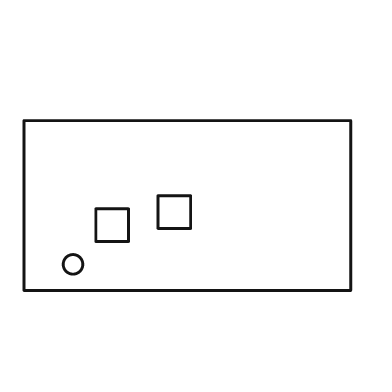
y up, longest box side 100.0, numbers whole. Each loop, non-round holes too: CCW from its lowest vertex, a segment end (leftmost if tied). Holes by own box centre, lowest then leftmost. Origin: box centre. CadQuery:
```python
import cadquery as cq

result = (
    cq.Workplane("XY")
    .moveTo(-50.0, -26.0)
    .lineTo(50.0, -26.0)
    .lineTo(50.0, 26.0)
    .lineTo(-50.0, 26.0)
    .close()
    .moveTo(-35.0, -18.0)
    .circle(3.0)
    .moveTo(-28.0, -11.0)
    .lineTo(-18.0, -11.0)
    .lineTo(-18.0, -1.0)
    .lineTo(-28.0, -1.0)
    .close()
    .moveTo(-9.0, -7.0)
    .lineTo(1.0, -7.0)
    .lineTo(1.0, 3.0)
    .lineTo(-9.0, 3.0)
    .close()
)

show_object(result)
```